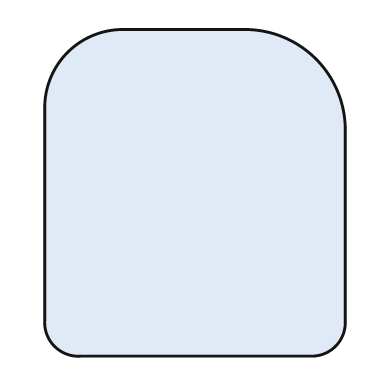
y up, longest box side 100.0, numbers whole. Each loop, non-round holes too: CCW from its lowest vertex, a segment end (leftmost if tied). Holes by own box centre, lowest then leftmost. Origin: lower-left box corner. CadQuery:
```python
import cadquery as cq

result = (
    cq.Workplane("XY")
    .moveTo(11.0, 0.0)
    .lineTo(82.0, 0.0)
    .threePointArc((89.0, 3.0), (92.0, 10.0))
    .lineTo(92.0, 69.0)
    .threePointArc((83.0, 91.0), (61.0, 100.0))
    .lineTo(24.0, 100.0)
    .threePointArc((7.0, 93.0), (0.0, 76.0))
    .lineTo(0.0, 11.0)
    .threePointArc((3.0, 3.0), (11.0, 0.0))
    .close()
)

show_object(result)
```